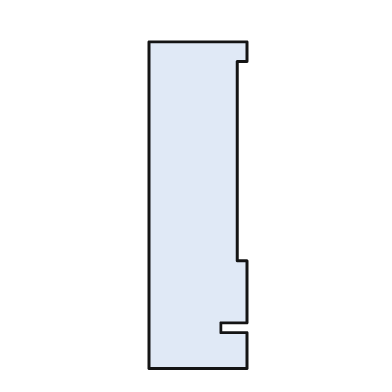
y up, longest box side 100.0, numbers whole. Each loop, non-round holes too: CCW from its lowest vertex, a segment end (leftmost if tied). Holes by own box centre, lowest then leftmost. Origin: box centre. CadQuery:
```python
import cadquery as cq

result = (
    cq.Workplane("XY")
    .moveTo(-15.0, -50.0)
    .lineTo(15.0, -50.0)
    .lineTo(15.0, -39.0)
    .lineTo(7.0, -39.0)
    .lineTo(7.0, -36.0)
    .lineTo(15.0, -36.0)
    .lineTo(15.0, -17.0)
    .lineTo(12.0, -17.0)
    .lineTo(12.0, 44.0)
    .lineTo(15.0, 44.0)
    .lineTo(15.0, 50.0)
    .lineTo(-15.0, 50.0)
    .close()
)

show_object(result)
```